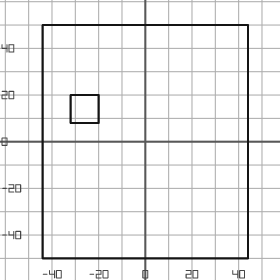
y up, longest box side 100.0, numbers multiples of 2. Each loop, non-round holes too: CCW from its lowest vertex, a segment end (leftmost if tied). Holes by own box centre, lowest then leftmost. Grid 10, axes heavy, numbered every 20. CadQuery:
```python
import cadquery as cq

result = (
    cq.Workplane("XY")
    .moveTo(-44.0, -50.0)
    .lineTo(44.0, -50.0)
    .lineTo(44.0, 50.0)
    .lineTo(-44.0, 50.0)
    .close()
    .moveTo(-32.0, 8.0)
    .lineTo(-20.0, 8.0)
    .lineTo(-20.0, 20.0)
    .lineTo(-32.0, 20.0)
    .close()
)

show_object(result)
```